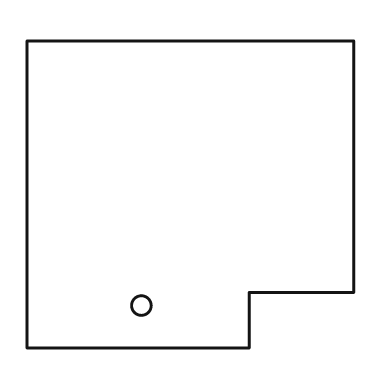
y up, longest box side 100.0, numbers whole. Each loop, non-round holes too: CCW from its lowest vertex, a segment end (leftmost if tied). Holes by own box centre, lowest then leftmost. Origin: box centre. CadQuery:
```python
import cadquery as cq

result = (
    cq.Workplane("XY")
    .moveTo(-50.0, -47.0)
    .lineTo(18.0, -47.0)
    .lineTo(18.0, -30.0)
    .lineTo(50.0, -30.0)
    .lineTo(50.0, 47.0)
    .lineTo(-50.0, 47.0)
    .close()
    .moveTo(-15.0, -34.0)
    .circle(3.0)
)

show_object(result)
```